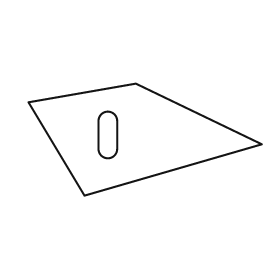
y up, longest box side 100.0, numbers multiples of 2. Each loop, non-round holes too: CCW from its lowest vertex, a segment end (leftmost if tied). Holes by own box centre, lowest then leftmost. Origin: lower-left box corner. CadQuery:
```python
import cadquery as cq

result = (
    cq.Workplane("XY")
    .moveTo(24.0, 0.0)
    .lineTo(100.0, 22.0)
    .lineTo(46.0, 48.0)
    .lineTo(0.0, 40.0)
    .close()
    .moveTo(30.0, 20.0)
    .threePointArc((34.0, 16.0), (38.0, 20.0))
    .lineTo(38.0, 32.0)
    .threePointArc((34.0, 36.0), (30.0, 32.0))
    .close()
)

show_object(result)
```